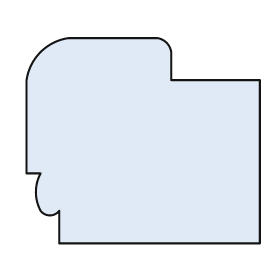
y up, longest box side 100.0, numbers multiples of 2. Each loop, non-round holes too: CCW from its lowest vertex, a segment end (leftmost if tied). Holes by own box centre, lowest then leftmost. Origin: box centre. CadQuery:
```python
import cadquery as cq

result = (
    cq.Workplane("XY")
    .moveTo(-36.0, -44.0)
    .lineTo(50.0, -44.0)
    .lineTo(50.0, 26.0)
    .lineTo(12.0, 26.0)
    .lineTo(12.0, 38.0)
    .threePointArc((10.0, 42.0), (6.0, 44.0))
    .lineTo(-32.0, 44.0)
    .threePointArc((-44.0, 38.0), (-50.0, 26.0))
    .lineTo(-50.0, -14.0)
    .lineTo(-44.0, -14.0)
    .threePointArc((-46.0, -22.0), (-44.0, -30.0))
    .threePointArc((-40.0, -32.0), (-36.0, -30.0))
    .close()
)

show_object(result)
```